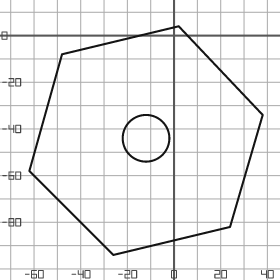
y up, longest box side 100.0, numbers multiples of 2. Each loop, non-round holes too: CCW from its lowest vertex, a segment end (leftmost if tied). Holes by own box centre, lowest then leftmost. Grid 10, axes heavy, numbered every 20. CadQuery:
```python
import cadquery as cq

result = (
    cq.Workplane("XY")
    .moveTo(-26.0, -94.0)
    .lineTo(24.0, -82.0)
    .lineTo(38.0, -34.0)
    .lineTo(2.0, 4.0)
    .lineTo(-48.0, -8.0)
    .lineTo(-62.0, -58.0)
    .close()
    .moveTo(-12.0, -44.0)
    .circle(10.0)
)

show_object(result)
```